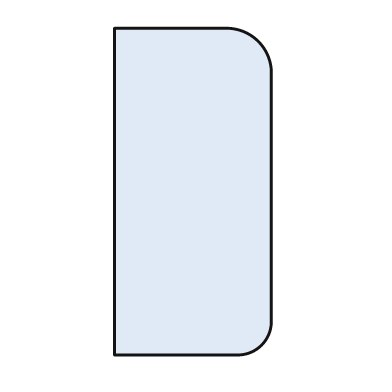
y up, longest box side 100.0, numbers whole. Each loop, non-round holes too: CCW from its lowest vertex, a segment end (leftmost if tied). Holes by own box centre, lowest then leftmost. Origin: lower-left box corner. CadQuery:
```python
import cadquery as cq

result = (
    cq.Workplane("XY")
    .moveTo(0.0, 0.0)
    .lineTo(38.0, 0.0)
    .threePointArc((45.0, 3.0), (48.0, 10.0))
    .lineTo(48.0, 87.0)
    .threePointArc((44.0, 96.0), (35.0, 100.0))
    .lineTo(0.0, 100.0)
    .close()
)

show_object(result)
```